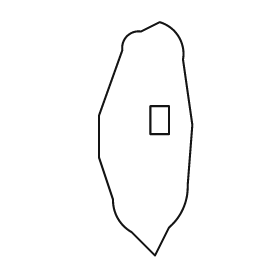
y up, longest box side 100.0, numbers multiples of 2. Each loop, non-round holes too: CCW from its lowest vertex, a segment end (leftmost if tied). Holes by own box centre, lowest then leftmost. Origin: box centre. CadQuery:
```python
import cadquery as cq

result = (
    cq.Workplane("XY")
    .moveTo(4.0, -50.0)
    .lineTo(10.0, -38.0)
    .threePointArc((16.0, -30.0), (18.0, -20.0))
    .lineTo(20.0, 6.0)
    .lineTo(16.0, 34.0)
    .threePointArc((14.0, 44.0), (6.0, 50.0))
    .lineTo(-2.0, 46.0)
    .threePointArc((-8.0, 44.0), (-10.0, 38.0))
    .lineTo(-20.0, 10.0)
    .lineTo(-20.0, -8.0)
    .lineTo(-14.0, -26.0)
    .threePointArc((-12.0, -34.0), (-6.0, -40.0))
    .close()
    .moveTo(2.0, 2.0)
    .lineTo(10.0, 2.0)
    .lineTo(10.0, 14.0)
    .lineTo(2.0, 14.0)
    .close()
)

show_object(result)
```